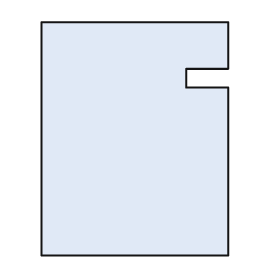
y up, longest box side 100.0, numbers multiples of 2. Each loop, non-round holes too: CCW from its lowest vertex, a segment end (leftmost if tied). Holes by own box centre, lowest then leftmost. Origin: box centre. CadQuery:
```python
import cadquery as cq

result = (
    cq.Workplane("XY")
    .moveTo(-40.0, -50.0)
    .lineTo(40.0, -50.0)
    .lineTo(40.0, 22.0)
    .lineTo(22.0, 22.0)
    .lineTo(22.0, 30.0)
    .lineTo(40.0, 30.0)
    .lineTo(40.0, 50.0)
    .lineTo(-40.0, 50.0)
    .close()
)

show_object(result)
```